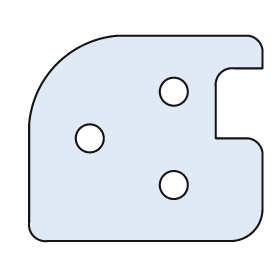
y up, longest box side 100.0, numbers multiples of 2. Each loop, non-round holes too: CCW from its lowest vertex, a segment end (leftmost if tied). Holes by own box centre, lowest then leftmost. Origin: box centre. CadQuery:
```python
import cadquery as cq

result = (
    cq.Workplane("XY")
    .moveTo(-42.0, -44.0)
    .lineTo(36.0, -44.0)
    .threePointArc((46.0, -40.0), (50.0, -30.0))
    .lineTo(50.0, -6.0)
    .threePointArc((48.0, -2.0), (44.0, 0.0))
    .lineTo(30.0, 0.0)
    .lineTo(30.0, 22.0)
    .threePointArc((32.0, 28.0), (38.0, 30.0))
    .lineTo(50.0, 30.0)
    .lineTo(50.0, 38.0)
    .threePointArc((48.0, 42.0), (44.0, 44.0))
    .lineTo(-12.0, 44.0)
    .threePointArc((-38.0, 32.0), (-50.0, 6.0))
    .lineTo(-50.0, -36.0)
    .threePointArc((-48.0, -42.0), (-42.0, -44.0))
    .close()
    .moveTo(12.0, -20.0)
    .circle(6.0)
    .moveTo(-24.0, 0.0)
    .circle(6.0)
    .moveTo(12.0, 20.0)
    .circle(6.0)
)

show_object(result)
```